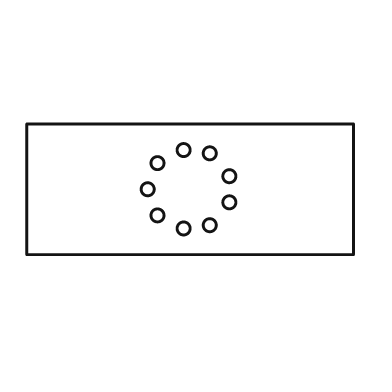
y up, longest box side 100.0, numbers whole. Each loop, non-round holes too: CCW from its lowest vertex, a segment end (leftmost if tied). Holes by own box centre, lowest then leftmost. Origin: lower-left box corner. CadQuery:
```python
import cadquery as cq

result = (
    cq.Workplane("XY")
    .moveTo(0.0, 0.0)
    .lineTo(100.0, 0.0)
    .lineTo(100.0, 40.0)
    .lineTo(0.0, 40.0)
    .close()
    .moveTo(48.0, 8.0)
    .circle(2.0)
    .moveTo(56.0, 9.0)
    .circle(2.0)
    .moveTo(40.0, 12.0)
    .circle(2.0)
    .moveTo(62.0, 16.0)
    .circle(2.0)
    .moveTo(37.0, 20.0)
    .circle(2.0)
    .moveTo(62.0, 24.0)
    .circle(2.0)
    .moveTo(40.0, 28.0)
    .circle(2.0)
    .moveTo(56.0, 31.0)
    .circle(2.0)
    .moveTo(48.0, 32.0)
    .circle(2.0)
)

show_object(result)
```